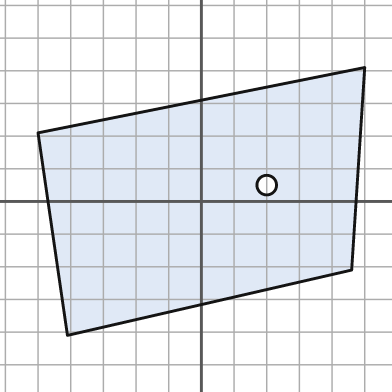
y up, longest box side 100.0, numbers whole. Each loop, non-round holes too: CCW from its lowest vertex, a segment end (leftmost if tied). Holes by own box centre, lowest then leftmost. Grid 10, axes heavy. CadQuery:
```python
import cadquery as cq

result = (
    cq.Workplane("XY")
    .moveTo(-41.0, -41.0)
    .lineTo(46.0, -21.0)
    .lineTo(50.0, 41.0)
    .lineTo(-50.0, 21.0)
    .close()
    .moveTo(20.0, 5.0)
    .circle(3.0)
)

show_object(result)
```